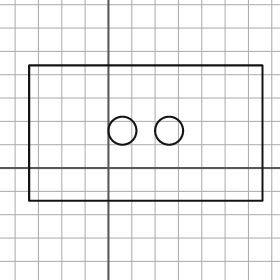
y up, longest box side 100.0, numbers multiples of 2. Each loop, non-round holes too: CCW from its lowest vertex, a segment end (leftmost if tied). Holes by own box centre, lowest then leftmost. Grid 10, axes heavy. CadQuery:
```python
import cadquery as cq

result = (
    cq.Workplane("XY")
    .moveTo(-34.0, -14.0)
    .lineTo(66.0, -14.0)
    .lineTo(66.0, 44.0)
    .lineTo(-34.0, 44.0)
    .close()
    .moveTo(6.0, 16.0)
    .circle(6.0)
    .moveTo(26.0, 16.0)
    .circle(6.0)
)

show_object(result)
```